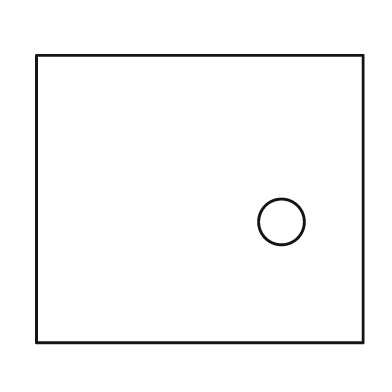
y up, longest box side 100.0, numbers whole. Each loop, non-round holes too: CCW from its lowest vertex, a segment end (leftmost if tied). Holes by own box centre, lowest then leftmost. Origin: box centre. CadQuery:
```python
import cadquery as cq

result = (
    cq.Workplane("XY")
    .moveTo(-50.0, -44.0)
    .lineTo(50.0, -44.0)
    .lineTo(50.0, 44.0)
    .lineTo(-50.0, 44.0)
    .close()
    .moveTo(25.0, -7.0)
    .circle(7.0)
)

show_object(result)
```